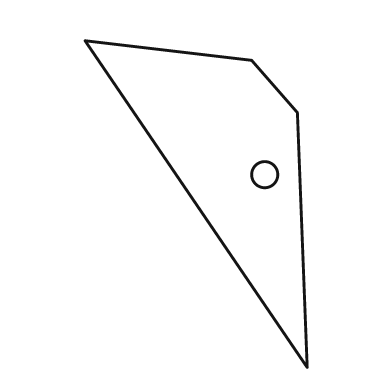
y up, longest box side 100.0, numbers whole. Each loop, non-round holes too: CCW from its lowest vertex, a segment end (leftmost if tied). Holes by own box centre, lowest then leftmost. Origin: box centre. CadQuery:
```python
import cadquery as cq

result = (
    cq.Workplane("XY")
    .moveTo(34.0, -50.0)
    .lineTo(31.0, 28.0)
    .lineTo(17.0, 44.0)
    .lineTo(-34.0, 50.0)
    .close()
    .moveTo(21.0, 9.0)
    .circle(4.0)
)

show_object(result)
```